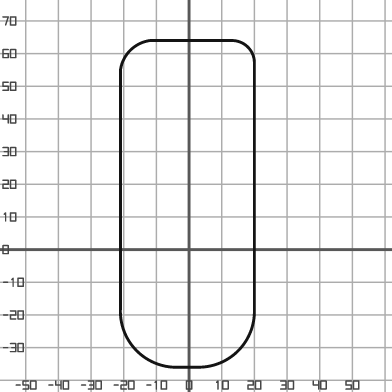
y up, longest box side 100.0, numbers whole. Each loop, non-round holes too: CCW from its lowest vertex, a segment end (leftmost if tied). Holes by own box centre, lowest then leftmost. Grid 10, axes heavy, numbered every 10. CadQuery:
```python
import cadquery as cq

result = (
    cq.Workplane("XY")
    .moveTo(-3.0, -36.0)
    .lineTo(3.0, -36.0)
    .threePointArc((15.0, -31.0), (20.0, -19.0))
    .lineTo(20.0, 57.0)
    .threePointArc((18.0, 62.0), (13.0, 64.0))
    .lineTo(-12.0, 64.0)
    .threePointArc((-18.0, 61.0), (-21.0, 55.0))
    .lineTo(-21.0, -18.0)
    .threePointArc((-16.0, -31.0), (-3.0, -36.0))
    .close()
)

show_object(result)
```